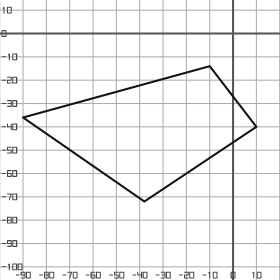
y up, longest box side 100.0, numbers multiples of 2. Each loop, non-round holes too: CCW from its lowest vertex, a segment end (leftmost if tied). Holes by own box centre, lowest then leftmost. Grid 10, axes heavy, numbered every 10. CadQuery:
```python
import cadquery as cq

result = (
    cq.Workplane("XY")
    .moveTo(-38.0, -72.0)
    .lineTo(10.0, -40.0)
    .lineTo(-10.0, -14.0)
    .lineTo(-90.0, -36.0)
    .close()
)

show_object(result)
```